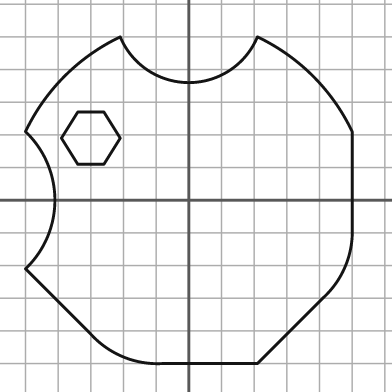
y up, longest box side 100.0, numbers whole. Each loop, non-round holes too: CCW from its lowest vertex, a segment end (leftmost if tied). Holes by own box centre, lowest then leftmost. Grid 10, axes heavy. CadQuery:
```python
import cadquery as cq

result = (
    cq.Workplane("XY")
    .moveTo(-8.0, -50.0)
    .lineTo(21.0, -50.0)
    .lineTo(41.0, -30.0)
    .threePointArc((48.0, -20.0), (50.0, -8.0))
    .lineTo(50.0, 21.0)
    .threePointArc((38.0, 38.0), (21.0, 50.0))
    .threePointArc((0.0, 36.0), (-21.0, 50.0))
    .threePointArc((-38.0, 38.0), (-50.0, 21.0))
    .threePointArc((-41.0, 0.0), (-50.0, -21.0))
    .lineTo(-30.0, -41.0)
    .threePointArc((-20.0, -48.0), (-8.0, -50.0))
    .close()
    .moveTo(-34.0, 11.0)
    .lineTo(-26.0, 11.0)
    .lineTo(-21.0, 19.0)
    .lineTo(-26.0, 27.0)
    .lineTo(-34.0, 27.0)
    .lineTo(-39.0, 19.0)
    .close()
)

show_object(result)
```